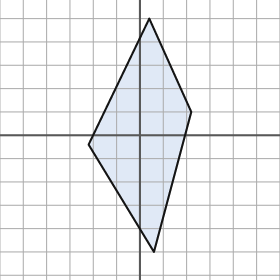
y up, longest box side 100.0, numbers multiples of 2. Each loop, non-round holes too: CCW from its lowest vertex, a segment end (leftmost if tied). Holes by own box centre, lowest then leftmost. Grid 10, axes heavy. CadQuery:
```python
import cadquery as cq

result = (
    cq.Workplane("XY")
    .moveTo(6.0, -50.0)
    .lineTo(22.0, 10.0)
    .lineTo(4.0, 50.0)
    .lineTo(-22.0, -4.0)
    .close()
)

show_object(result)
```